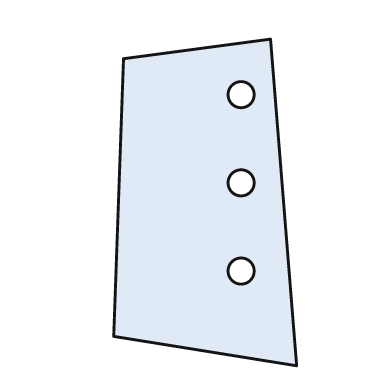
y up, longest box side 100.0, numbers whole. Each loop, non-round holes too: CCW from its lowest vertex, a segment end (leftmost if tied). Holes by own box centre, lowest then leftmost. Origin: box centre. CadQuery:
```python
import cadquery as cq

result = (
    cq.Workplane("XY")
    .moveTo(28.0, -50.0)
    .lineTo(20.0, 50.0)
    .lineTo(-25.0, 44.0)
    .lineTo(-28.0, -41.0)
    .close()
    .moveTo(11.0, -21.0)
    .circle(4.0)
    .moveTo(11.0, 6.0)
    .circle(4.0)
    .moveTo(11.0, 33.0)
    .circle(4.0)
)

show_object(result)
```